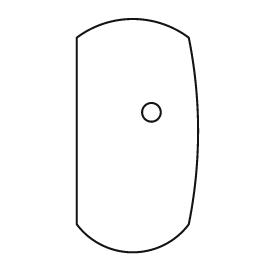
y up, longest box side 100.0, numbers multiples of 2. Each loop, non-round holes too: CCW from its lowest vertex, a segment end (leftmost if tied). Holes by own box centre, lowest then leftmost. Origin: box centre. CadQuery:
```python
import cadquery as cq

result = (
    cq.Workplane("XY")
    .moveTo(-26.0, -38.0)
    .threePointArc((-2.0, -50.0), (22.0, -38.0))
    .threePointArc((26.0, 2.0), (22.0, 42.0))
    .threePointArc((-2.0, 50.0), (-26.0, 42.0))
    .close()
    .moveTo(6.0, 10.0)
    .circle(4.0)
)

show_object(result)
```